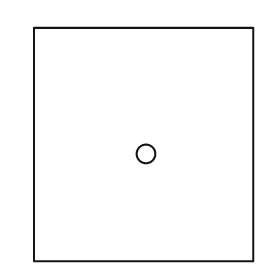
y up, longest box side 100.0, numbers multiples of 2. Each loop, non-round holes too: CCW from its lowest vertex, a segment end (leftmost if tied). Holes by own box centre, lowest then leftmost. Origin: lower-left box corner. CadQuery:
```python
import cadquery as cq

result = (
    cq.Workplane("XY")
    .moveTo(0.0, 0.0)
    .lineTo(94.0, 0.0)
    .lineTo(94.0, 100.0)
    .lineTo(0.0, 100.0)
    .close()
    .moveTo(48.0, 46.0)
    .circle(4.0)
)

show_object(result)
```